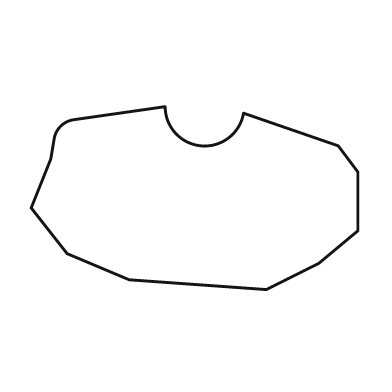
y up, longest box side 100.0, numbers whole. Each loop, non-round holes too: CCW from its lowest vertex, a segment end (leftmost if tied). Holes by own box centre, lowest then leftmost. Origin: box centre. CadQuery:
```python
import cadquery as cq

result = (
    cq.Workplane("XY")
    .moveTo(22.0, -28.0)
    .lineTo(38.0, -20.0)
    .lineTo(50.0, -10.0)
    .lineTo(50.0, 8.0)
    .lineTo(44.0, 16.0)
    .lineTo(15.0, 26.0)
    .threePointArc((2.0, 16.0), (-9.0, 28.0))
    .lineTo(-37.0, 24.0)
    .threePointArc((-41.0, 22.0), (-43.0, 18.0))
    .lineTo(-44.0, 12.0)
    .lineTo(-50.0, -3.0)
    .lineTo(-39.0, -17.0)
    .lineTo(-20.0, -25.0)
    .close()
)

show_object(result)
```